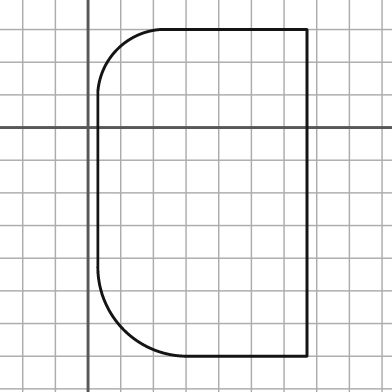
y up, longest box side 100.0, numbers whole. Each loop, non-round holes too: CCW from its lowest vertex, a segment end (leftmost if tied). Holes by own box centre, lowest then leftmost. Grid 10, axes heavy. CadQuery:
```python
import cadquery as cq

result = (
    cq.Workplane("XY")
    .moveTo(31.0, -70.0)
    .lineTo(67.0, -70.0)
    .lineTo(67.0, 30.0)
    .lineTo(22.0, 30.0)
    .threePointArc((9.0, 24.0), (3.0, 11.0))
    .lineTo(3.0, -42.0)
    .threePointArc((11.0, -62.0), (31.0, -70.0))
    .close()
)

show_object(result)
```